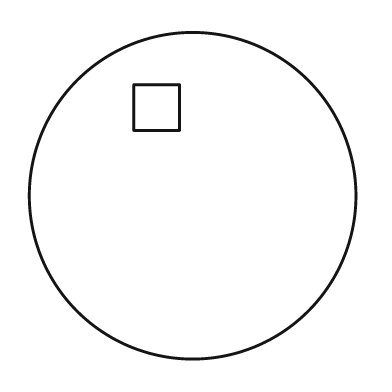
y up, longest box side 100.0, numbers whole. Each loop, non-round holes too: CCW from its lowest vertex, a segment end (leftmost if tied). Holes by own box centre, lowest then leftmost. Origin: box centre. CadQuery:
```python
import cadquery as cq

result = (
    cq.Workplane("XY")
    .moveTo(0.0, 0.0)
    .circle(50.0)
    .moveTo(-18.0, 20.0)
    .lineTo(-4.0, 20.0)
    .lineTo(-4.0, 34.0)
    .lineTo(-18.0, 34.0)
    .close()
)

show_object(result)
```